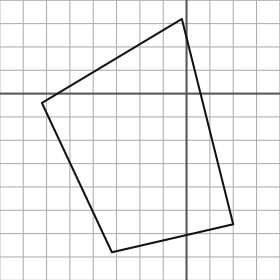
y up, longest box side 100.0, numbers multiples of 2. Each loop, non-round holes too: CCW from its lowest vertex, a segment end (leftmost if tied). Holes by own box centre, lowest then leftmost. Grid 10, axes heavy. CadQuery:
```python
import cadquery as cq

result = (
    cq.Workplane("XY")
    .moveTo(-32.0, -68.0)
    .lineTo(20.0, -56.0)
    .lineTo(-2.0, 32.0)
    .lineTo(-62.0, -4.0)
    .close()
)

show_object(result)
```